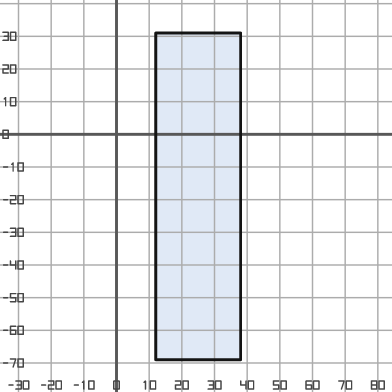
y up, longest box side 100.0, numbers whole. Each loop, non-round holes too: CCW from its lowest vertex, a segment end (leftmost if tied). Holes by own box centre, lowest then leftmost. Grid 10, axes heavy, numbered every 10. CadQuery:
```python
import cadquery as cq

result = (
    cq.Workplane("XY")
    .moveTo(12.0, -69.0)
    .lineTo(38.0, -69.0)
    .lineTo(38.0, 31.0)
    .lineTo(12.0, 31.0)
    .close()
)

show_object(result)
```